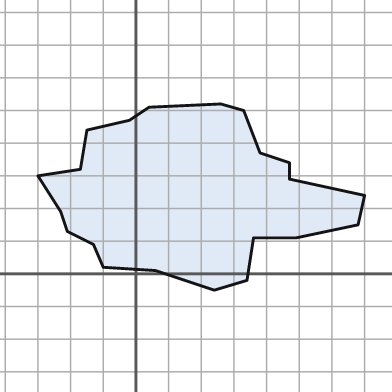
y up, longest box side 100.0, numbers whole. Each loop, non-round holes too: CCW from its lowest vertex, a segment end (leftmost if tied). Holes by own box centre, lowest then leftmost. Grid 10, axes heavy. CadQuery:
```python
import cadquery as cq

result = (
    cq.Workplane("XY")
    .moveTo(24.0, -5.0)
    .lineTo(34.0, -2.0)
    .lineTo(36.0, 11.0)
    .lineTo(49.0, 11.0)
    .lineTo(68.0, 15.0)
    .lineTo(70.0, 24.0)
    .lineTo(47.0, 29.0)
    .lineTo(47.0, 34.0)
    .lineTo(38.0, 37.0)
    .lineTo(33.0, 50.0)
    .lineTo(26.0, 52.0)
    .lineTo(4.0, 51.0)
    .lineTo(-2.0, 47.0)
    .lineTo(-15.0, 44.0)
    .lineTo(-17.0, 32.0)
    .lineTo(-30.0, 30.0)
    .lineTo(-23.0, 19.0)
    .lineTo(-21.0, 13.0)
    .lineTo(-13.0, 9.0)
    .lineTo(-10.0, 2.0)
    .lineTo(6.0, 1.0)
    .close()
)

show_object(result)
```